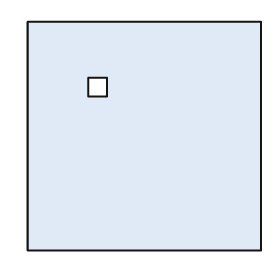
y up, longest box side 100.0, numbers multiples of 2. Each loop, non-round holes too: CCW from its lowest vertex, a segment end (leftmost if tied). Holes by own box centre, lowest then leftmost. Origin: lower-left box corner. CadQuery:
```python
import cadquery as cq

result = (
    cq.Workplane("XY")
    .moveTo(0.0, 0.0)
    .lineTo(100.0, 0.0)
    .lineTo(100.0, 98.0)
    .lineTo(0.0, 98.0)
    .close()
    .moveTo(26.0, 66.0)
    .lineTo(34.0, 66.0)
    .lineTo(34.0, 74.0)
    .lineTo(26.0, 74.0)
    .close()
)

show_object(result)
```